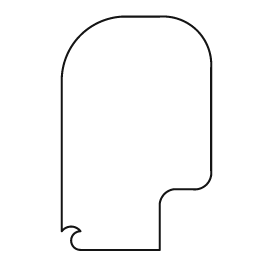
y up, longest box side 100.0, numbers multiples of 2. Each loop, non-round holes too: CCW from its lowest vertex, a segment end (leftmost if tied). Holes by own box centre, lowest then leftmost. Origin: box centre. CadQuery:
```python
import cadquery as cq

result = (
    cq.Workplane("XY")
    .moveTo(-24.0, -50.0)
    .lineTo(10.0, -50.0)
    .lineTo(10.0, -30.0)
    .threePointArc((12.0, -26.0), (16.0, -24.0))
    .lineTo(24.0, -24.0)
    .threePointArc((30.0, -22.0), (32.0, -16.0))
    .lineTo(32.0, 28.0)
    .threePointArc((26.0, 44.0), (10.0, 50.0))
    .lineTo(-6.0, 50.0)
    .threePointArc((-24.0, 42.0), (-32.0, 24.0))
    .lineTo(-32.0, -42.0)
    .threePointArc((-28.0, -40.0), (-24.0, -42.0))
    .threePointArc((-28.0, -46.0), (-24.0, -50.0))
    .close()
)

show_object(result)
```